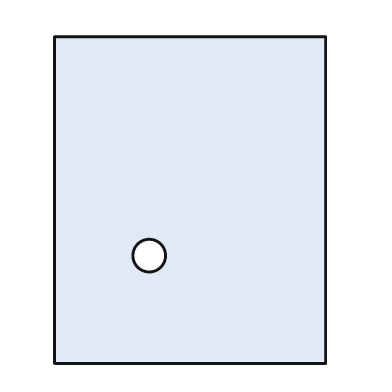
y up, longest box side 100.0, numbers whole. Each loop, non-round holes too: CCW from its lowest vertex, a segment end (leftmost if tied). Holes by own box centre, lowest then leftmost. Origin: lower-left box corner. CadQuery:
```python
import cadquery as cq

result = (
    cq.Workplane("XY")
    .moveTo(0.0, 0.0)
    .lineTo(83.0, 0.0)
    .lineTo(83.0, 100.0)
    .lineTo(0.0, 100.0)
    .close()
    .moveTo(29.0, 33.0)
    .circle(5.0)
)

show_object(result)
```